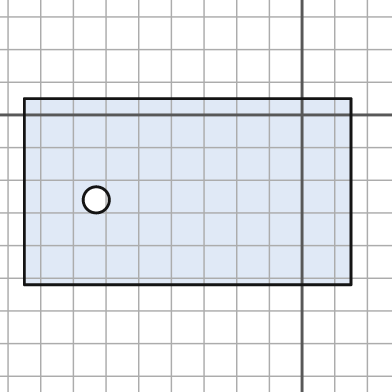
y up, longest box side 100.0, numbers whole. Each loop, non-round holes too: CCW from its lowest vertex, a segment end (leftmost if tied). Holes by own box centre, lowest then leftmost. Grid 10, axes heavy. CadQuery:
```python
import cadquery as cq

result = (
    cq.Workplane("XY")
    .moveTo(-85.0, -52.0)
    .lineTo(15.0, -52.0)
    .lineTo(15.0, 5.0)
    .lineTo(-85.0, 5.0)
    .close()
    .moveTo(-63.0, -26.0)
    .circle(4.0)
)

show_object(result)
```